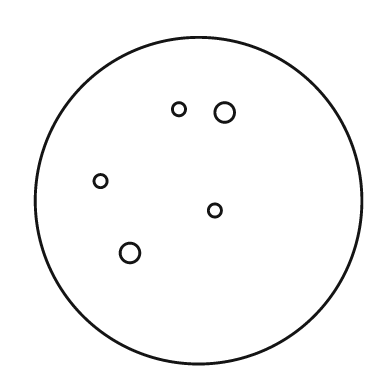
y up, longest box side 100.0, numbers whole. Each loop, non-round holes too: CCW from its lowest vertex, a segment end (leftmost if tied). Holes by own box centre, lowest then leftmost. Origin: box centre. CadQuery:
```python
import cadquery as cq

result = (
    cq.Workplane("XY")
    .moveTo(0.0, 0.0)
    .circle(50.0)
    .moveTo(-21.0, -16.0)
    .circle(3.0)
    .moveTo(5.0, -3.0)
    .circle(2.0)
    .moveTo(-30.0, 6.0)
    .circle(2.0)
    .moveTo(8.0, 27.0)
    .circle(3.0)
    .moveTo(-6.0, 28.0)
    .circle(2.0)
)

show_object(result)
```